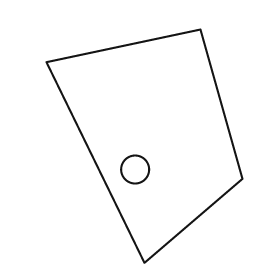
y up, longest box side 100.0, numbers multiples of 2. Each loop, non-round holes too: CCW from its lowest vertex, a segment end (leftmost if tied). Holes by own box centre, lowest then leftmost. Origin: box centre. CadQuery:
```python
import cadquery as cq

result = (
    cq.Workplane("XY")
    .moveTo(0.0, -50.0)
    .lineTo(42.0, -14.0)
    .lineTo(24.0, 50.0)
    .lineTo(-42.0, 36.0)
    .close()
    .moveTo(-4.0, -10.0)
    .circle(6.0)
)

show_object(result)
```